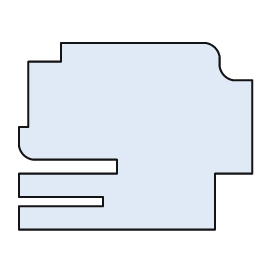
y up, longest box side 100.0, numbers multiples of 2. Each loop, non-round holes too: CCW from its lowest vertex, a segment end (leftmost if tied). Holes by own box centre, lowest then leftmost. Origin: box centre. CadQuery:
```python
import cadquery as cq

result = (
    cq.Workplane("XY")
    .moveTo(-50.0, -40.0)
    .lineTo(34.0, -40.0)
    .lineTo(34.0, -16.0)
    .lineTo(50.0, -16.0)
    .lineTo(50.0, 24.0)
    .lineTo(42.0, 24.0)
    .threePointArc((38.0, 26.0), (36.0, 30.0))
    .lineTo(36.0, 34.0)
    .threePointArc((34.0, 38.0), (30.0, 40.0))
    .lineTo(-32.0, 40.0)
    .lineTo(-32.0, 32.0)
    .lineTo(-46.0, 32.0)
    .lineTo(-46.0, 4.0)
    .lineTo(-50.0, 4.0)
    .lineTo(-50.0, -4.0)
    .threePointArc((-48.0, -8.0), (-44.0, -10.0))
    .lineTo(-8.0, -10.0)
    .lineTo(-8.0, -16.0)
    .lineTo(-50.0, -16.0)
    .lineTo(-50.0, -26.0)
    .lineTo(-14.0, -26.0)
    .lineTo(-14.0, -30.0)
    .lineTo(-50.0, -30.0)
    .close()
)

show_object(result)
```